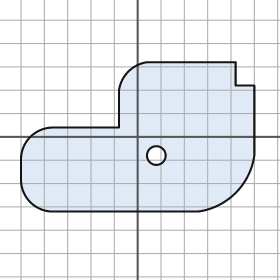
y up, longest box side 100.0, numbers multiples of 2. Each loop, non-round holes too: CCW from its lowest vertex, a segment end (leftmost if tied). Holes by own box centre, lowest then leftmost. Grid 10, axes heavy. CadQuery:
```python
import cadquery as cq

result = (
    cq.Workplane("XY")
    .moveTo(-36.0, -32.0)
    .lineTo(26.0, -32.0)
    .threePointArc((42.0, -24.0), (50.0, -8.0))
    .lineTo(50.0, 22.0)
    .lineTo(42.0, 22.0)
    .lineTo(42.0, 32.0)
    .lineTo(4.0, 32.0)
    .threePointArc((-4.0, 28.0), (-8.0, 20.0))
    .lineTo(-8.0, 4.0)
    .lineTo(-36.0, 4.0)
    .threePointArc((-46.0, 0.0), (-50.0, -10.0))
    .lineTo(-50.0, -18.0)
    .threePointArc((-46.0, -28.0), (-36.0, -32.0))
    .close()
    .moveTo(8.0, -8.0)
    .circle(4.0)
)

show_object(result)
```